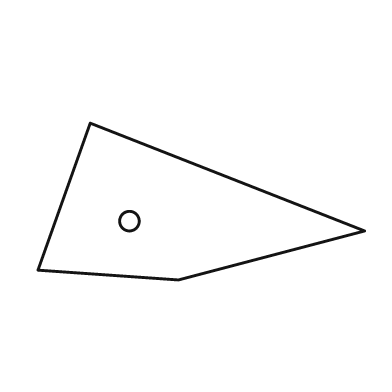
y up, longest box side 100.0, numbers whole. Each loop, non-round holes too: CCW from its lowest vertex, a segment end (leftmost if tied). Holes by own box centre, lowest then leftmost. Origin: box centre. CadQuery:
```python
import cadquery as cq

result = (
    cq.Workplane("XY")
    .moveTo(-7.0, -24.0)
    .lineTo(50.0, -9.0)
    .lineTo(-34.0, 24.0)
    .lineTo(-50.0, -21.0)
    .close()
    .moveTo(-22.0, -6.0)
    .circle(3.0)
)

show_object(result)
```